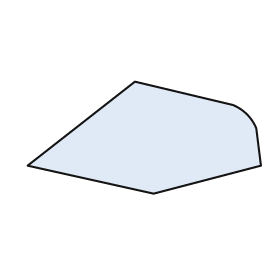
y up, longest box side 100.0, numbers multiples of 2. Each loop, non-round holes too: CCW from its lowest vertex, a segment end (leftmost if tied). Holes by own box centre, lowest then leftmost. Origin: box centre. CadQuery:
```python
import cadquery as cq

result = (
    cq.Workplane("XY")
    .moveTo(4.0, -24.0)
    .lineTo(50.0, -12.0)
    .lineTo(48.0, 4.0)
    .threePointArc((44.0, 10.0), (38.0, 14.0))
    .lineTo(-4.0, 24.0)
    .lineTo(-50.0, -12.0)
    .close()
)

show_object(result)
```